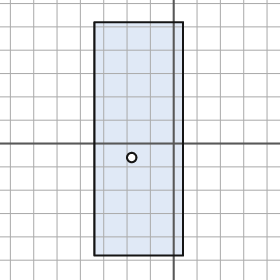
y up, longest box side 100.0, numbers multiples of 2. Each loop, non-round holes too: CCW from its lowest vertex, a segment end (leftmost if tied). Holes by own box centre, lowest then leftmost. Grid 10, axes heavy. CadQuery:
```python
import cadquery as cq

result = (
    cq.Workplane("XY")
    .moveTo(-34.0, -48.0)
    .lineTo(4.0, -48.0)
    .lineTo(4.0, 52.0)
    .lineTo(-34.0, 52.0)
    .close()
    .moveTo(-18.0, -6.0)
    .circle(2.0)
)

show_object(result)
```